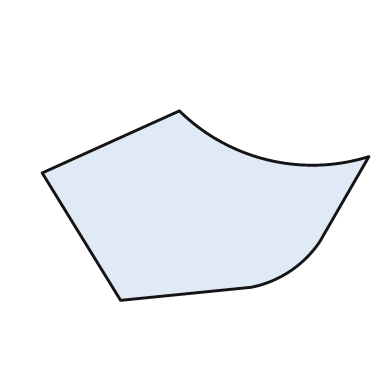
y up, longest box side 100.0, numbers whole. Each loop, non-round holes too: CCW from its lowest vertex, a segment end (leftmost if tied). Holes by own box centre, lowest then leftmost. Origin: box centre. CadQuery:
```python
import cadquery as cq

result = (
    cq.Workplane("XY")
    .moveTo(-26.0, -29.0)
    .lineTo(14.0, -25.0)
    .threePointArc((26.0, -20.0), (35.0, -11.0))
    .lineTo(50.0, 15.0)
    .threePointArc((19.0, 14.0), (-8.0, 29.0))
    .lineTo(-50.0, 10.0)
    .close()
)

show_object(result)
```